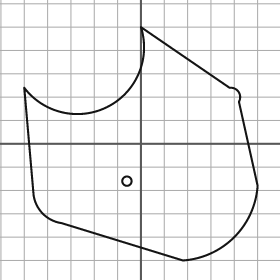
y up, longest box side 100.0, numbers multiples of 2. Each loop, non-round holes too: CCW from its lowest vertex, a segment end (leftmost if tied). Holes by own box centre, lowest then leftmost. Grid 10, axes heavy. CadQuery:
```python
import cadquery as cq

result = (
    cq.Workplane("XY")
    .moveTo(18.0, -50.0)
    .threePointArc((40.0, -40.0), (50.0, -18.0))
    .lineTo(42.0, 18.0)
    .threePointArc((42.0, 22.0), (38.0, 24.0))
    .lineTo(0.0, 50.0)
    .threePointArc((-14.0, 16.0), (-50.0, 24.0))
    .lineTo(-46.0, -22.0)
    .threePointArc((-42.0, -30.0), (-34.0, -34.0))
    .close()
    .moveTo(-6.0, -16.0)
    .circle(2.0)
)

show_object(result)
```